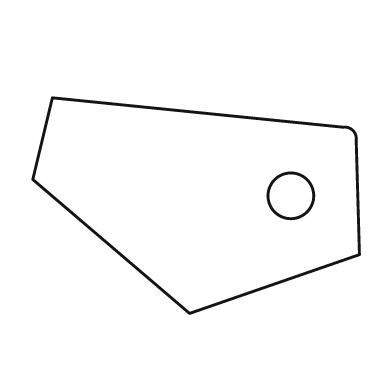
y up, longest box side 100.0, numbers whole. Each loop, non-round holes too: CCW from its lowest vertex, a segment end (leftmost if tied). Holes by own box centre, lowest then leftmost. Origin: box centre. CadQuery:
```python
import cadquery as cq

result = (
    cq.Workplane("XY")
    .moveTo(-2.0, -33.0)
    .lineTo(50.0, -15.0)
    .lineTo(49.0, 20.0)
    .threePointArc((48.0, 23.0), (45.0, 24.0))
    .lineTo(-44.0, 33.0)
    .lineTo(-50.0, 8.0)
    .close()
    .moveTo(29.0, 3.0)
    .circle(7.0)
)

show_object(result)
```